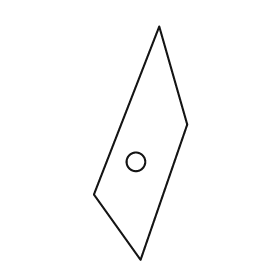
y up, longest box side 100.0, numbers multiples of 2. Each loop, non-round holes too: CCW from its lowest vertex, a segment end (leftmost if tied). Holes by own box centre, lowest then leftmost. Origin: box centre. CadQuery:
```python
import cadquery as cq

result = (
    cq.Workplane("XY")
    .moveTo(0.0, -50.0)
    .lineTo(20.0, 8.0)
    .lineTo(8.0, 50.0)
    .lineTo(-20.0, -22.0)
    .close()
    .moveTo(-2.0, -8.0)
    .circle(4.0)
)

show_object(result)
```